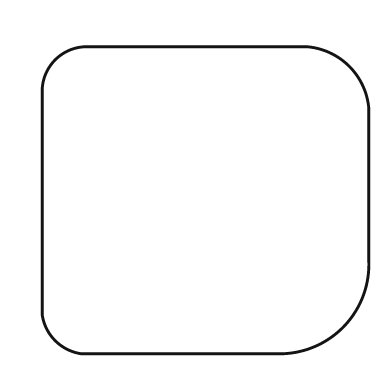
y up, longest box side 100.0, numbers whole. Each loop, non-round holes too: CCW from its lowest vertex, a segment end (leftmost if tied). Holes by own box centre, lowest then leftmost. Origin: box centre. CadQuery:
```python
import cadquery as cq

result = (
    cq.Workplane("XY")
    .moveTo(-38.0, -47.0)
    .lineTo(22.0, -47.0)
    .threePointArc((42.0, -39.0), (50.0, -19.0))
    .lineTo(50.0, 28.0)
    .threePointArc((44.0, 41.0), (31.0, 47.0))
    .lineTo(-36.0, 47.0)
    .threePointArc((-46.0, 43.0), (-50.0, 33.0))
    .lineTo(-50.0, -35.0)
    .threePointArc((-46.0, -43.0), (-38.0, -47.0))
    .close()
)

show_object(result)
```